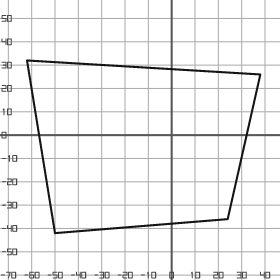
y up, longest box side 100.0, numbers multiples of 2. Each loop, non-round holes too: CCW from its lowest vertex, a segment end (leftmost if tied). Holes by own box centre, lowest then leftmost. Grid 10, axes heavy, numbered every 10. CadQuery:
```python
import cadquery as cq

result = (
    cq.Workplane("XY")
    .moveTo(-50.0, -42.0)
    .lineTo(24.0, -36.0)
    .lineTo(38.0, 26.0)
    .lineTo(-62.0, 32.0)
    .close()
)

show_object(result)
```